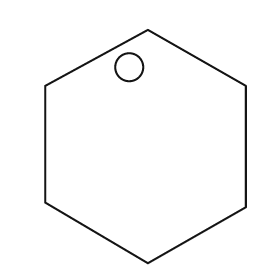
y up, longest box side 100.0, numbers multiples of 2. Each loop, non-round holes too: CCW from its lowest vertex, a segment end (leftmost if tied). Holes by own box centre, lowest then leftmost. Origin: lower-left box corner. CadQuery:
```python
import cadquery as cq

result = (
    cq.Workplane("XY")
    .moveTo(44.0, 0.0)
    .lineTo(86.0, 24.0)
    .lineTo(86.0, 76.0)
    .lineTo(44.0, 100.0)
    .lineTo(0.0, 76.0)
    .lineTo(0.0, 26.0)
    .close()
    .moveTo(36.0, 84.0)
    .circle(6.0)
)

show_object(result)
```